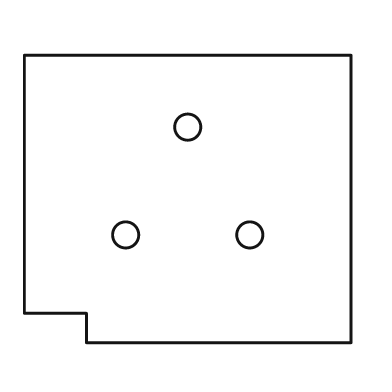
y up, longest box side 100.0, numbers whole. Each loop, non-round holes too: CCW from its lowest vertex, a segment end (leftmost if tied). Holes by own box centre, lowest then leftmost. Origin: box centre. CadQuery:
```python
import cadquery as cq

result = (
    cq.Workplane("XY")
    .moveTo(-31.0, -44.0)
    .lineTo(50.0, -44.0)
    .lineTo(50.0, 44.0)
    .lineTo(-50.0, 44.0)
    .lineTo(-50.0, -35.0)
    .lineTo(-31.0, -35.0)
    .close()
    .moveTo(-19.0, -11.0)
    .circle(4.0)
    .moveTo(19.0, -11.0)
    .circle(4.0)
    .moveTo(0.0, 22.0)
    .circle(4.0)
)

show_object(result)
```